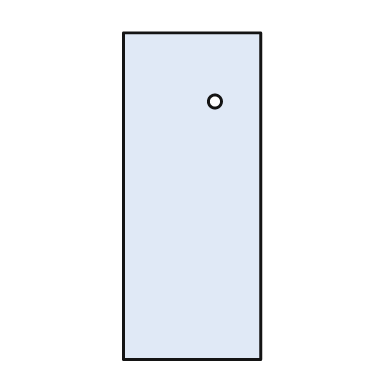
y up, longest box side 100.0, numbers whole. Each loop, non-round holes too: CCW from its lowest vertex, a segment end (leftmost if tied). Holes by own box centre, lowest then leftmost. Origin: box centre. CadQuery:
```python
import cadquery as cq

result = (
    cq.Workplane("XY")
    .moveTo(-21.0, -50.0)
    .lineTo(21.0, -50.0)
    .lineTo(21.0, 50.0)
    .lineTo(-21.0, 50.0)
    .close()
    .moveTo(7.0, 29.0)
    .circle(2.0)
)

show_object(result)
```